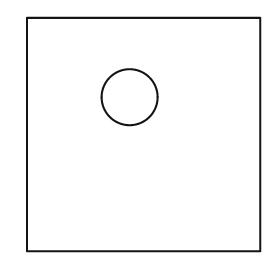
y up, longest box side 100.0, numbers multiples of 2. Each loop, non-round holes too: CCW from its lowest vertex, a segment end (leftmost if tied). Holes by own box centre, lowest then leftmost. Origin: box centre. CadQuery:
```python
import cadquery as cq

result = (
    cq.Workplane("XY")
    .moveTo(-50.0, -50.0)
    .lineTo(50.0, -50.0)
    .lineTo(50.0, 50.0)
    .lineTo(-50.0, 50.0)
    .close()
    .moveTo(-6.0, 16.0)
    .circle(12.0)
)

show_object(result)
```